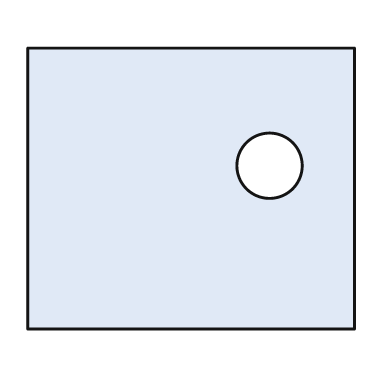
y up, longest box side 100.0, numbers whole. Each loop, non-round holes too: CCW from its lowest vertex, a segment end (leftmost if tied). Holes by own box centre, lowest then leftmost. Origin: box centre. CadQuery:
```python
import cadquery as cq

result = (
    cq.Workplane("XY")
    .moveTo(-50.0, -43.0)
    .lineTo(50.0, -43.0)
    .lineTo(50.0, 43.0)
    .lineTo(-50.0, 43.0)
    .close()
    .moveTo(24.0, 7.0)
    .circle(10.0)
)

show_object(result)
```